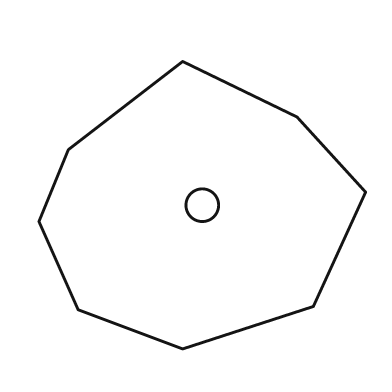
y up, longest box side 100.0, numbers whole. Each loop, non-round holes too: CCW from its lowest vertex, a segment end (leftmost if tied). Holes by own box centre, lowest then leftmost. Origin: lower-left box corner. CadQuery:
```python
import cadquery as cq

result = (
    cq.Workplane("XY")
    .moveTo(44.0, 0.0)
    .lineTo(84.0, 13.0)
    .lineTo(100.0, 48.0)
    .lineTo(79.0, 71.0)
    .lineTo(44.0, 88.0)
    .lineTo(9.0, 61.0)
    .lineTo(0.0, 39.0)
    .lineTo(12.0, 12.0)
    .close()
    .moveTo(50.0, 44.0)
    .circle(5.0)
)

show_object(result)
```